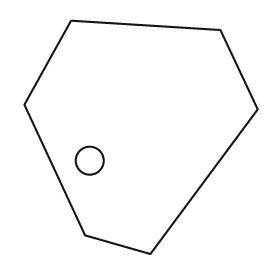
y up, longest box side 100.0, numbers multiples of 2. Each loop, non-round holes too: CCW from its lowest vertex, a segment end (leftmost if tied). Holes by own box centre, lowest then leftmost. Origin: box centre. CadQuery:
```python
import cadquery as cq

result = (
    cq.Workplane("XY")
    .moveTo(4.0, -50.0)
    .lineTo(50.0, 12.0)
    .lineTo(34.0, 46.0)
    .lineTo(-30.0, 50.0)
    .lineTo(-50.0, 14.0)
    .lineTo(-24.0, -42.0)
    .close()
    .moveTo(-22.0, -10.0)
    .circle(6.0)
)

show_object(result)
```